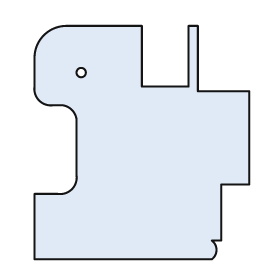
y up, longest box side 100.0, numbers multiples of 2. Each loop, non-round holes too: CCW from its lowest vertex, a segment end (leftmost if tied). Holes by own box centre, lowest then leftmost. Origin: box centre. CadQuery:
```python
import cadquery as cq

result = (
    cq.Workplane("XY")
    .moveTo(-46.0, -50.0)
    .lineTo(30.0, -50.0)
    .threePointArc((32.0, -46.0), (30.0, -42.0))
    .lineTo(34.0, -42.0)
    .lineTo(34.0, -18.0)
    .lineTo(46.0, -18.0)
    .lineTo(46.0, 22.0)
    .lineTo(24.0, 22.0)
    .lineTo(24.0, 50.0)
    .lineTo(20.0, 50.0)
    .lineTo(20.0, 24.0)
    .lineTo(0.0, 24.0)
    .lineTo(0.0, 50.0)
    .lineTo(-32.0, 50.0)
    .threePointArc((-42.0, 46.0), (-46.0, 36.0))
    .lineTo(-46.0, 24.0)
    .threePointArc((-44.0, 18.0), (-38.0, 16.0))
    .lineTo(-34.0, 16.0)
    .threePointArc((-30.0, 14.0), (-28.0, 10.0))
    .lineTo(-28.0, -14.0)
    .threePointArc((-30.0, -20.0), (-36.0, -22.0))
    .lineTo(-46.0, -22.0)
    .close()
    .moveTo(-26.0, 30.0)
    .circle(2.0)
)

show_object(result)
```